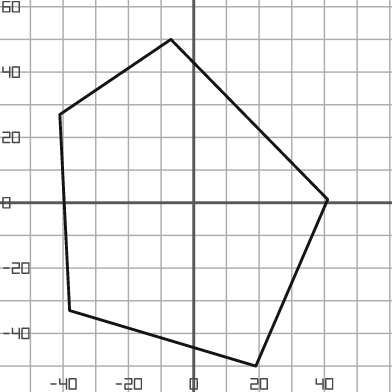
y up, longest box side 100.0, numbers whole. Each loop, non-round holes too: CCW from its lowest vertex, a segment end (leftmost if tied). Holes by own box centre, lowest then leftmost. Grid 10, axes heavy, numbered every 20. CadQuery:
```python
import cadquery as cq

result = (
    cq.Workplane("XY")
    .moveTo(19.0, -50.0)
    .lineTo(41.0, 1.0)
    .lineTo(-7.0, 50.0)
    .lineTo(-41.0, 27.0)
    .lineTo(-38.0, -33.0)
    .close()
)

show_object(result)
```